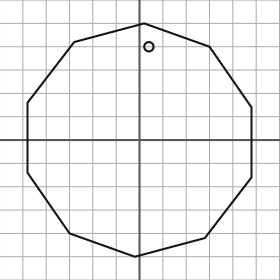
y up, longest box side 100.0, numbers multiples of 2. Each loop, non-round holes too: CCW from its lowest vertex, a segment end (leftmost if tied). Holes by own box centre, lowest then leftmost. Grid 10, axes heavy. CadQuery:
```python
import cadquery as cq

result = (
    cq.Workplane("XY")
    .moveTo(-2.0, -50.0)
    .lineTo(28.0, -42.0)
    .lineTo(48.0, -16.0)
    .lineTo(48.0, 14.0)
    .lineTo(30.0, 40.0)
    .lineTo(2.0, 50.0)
    .lineTo(-28.0, 42.0)
    .lineTo(-48.0, 16.0)
    .lineTo(-48.0, -14.0)
    .lineTo(-30.0, -40.0)
    .close()
    .moveTo(4.0, 40.0)
    .circle(2.0)
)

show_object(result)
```